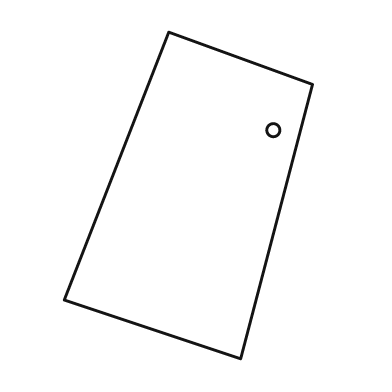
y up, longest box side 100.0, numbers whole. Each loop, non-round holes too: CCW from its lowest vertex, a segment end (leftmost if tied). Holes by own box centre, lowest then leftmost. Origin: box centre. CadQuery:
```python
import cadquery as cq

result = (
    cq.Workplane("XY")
    .moveTo(16.0, -50.0)
    .lineTo(38.0, 34.0)
    .lineTo(-6.0, 50.0)
    .lineTo(-38.0, -32.0)
    .close()
    .moveTo(26.0, 20.0)
    .circle(2.0)
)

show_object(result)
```